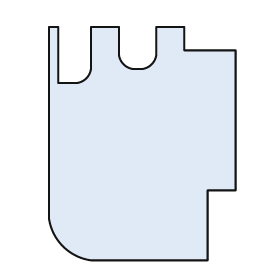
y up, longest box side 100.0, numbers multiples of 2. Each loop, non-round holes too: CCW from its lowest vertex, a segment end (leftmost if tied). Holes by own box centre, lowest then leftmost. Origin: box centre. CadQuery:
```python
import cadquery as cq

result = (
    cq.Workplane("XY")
    .moveTo(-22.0, -50.0)
    .lineTo(28.0, -50.0)
    .lineTo(28.0, -20.0)
    .lineTo(40.0, -20.0)
    .lineTo(40.0, 40.0)
    .lineTo(18.0, 40.0)
    .lineTo(18.0, 50.0)
    .lineTo(6.0, 50.0)
    .lineTo(6.0, 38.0)
    .threePointArc((4.0, 34.0), (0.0, 32.0))
    .lineTo(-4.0, 32.0)
    .threePointArc((-8.0, 34.0), (-10.0, 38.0))
    .lineTo(-10.0, 50.0)
    .lineTo(-22.0, 50.0)
    .lineTo(-22.0, 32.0)
    .threePointArc((-24.0, 28.0), (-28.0, 26.0))
    .lineTo(-36.0, 26.0)
    .lineTo(-36.0, 50.0)
    .lineTo(-40.0, 50.0)
    .lineTo(-40.0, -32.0)
    .threePointArc((-34.0, -44.0), (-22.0, -50.0))
    .close()
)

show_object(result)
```